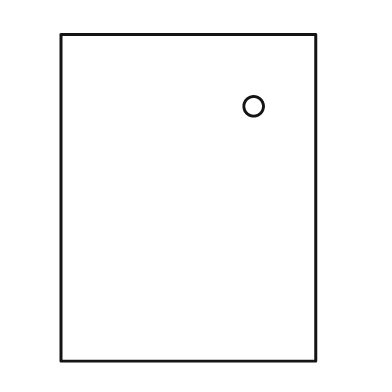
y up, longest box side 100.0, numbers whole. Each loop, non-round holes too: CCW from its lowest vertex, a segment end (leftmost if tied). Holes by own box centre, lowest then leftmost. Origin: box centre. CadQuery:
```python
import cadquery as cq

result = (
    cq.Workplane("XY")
    .moveTo(-39.0, -50.0)
    .lineTo(39.0, -50.0)
    .lineTo(39.0, 50.0)
    .lineTo(-39.0, 50.0)
    .close()
    .moveTo(20.0, 28.0)
    .circle(3.0)
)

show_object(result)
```